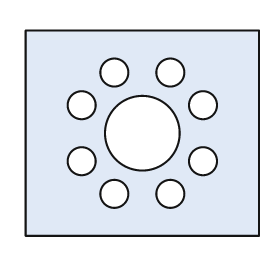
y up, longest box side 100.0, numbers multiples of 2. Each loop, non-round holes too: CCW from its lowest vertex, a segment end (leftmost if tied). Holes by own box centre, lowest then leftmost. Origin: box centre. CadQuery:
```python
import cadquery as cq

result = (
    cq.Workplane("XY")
    .moveTo(-50.0, -44.0)
    .lineTo(50.0, -44.0)
    .lineTo(50.0, 44.0)
    .lineTo(-50.0, 44.0)
    .close()
    .moveTo(-12.0, -26.0)
    .circle(6.0)
    .moveTo(12.0, -26.0)
    .circle(6.0)
    .moveTo(-26.0, -12.0)
    .circle(6.0)
    .moveTo(26.0, -12.0)
    .circle(6.0)
    .moveTo(0.0, 0.0)
    .circle(16.0)
    .moveTo(-26.0, 12.0)
    .circle(6.0)
    .moveTo(26.0, 12.0)
    .circle(6.0)
    .moveTo(-12.0, 26.0)
    .circle(6.0)
    .moveTo(12.0, 26.0)
    .circle(6.0)
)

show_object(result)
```